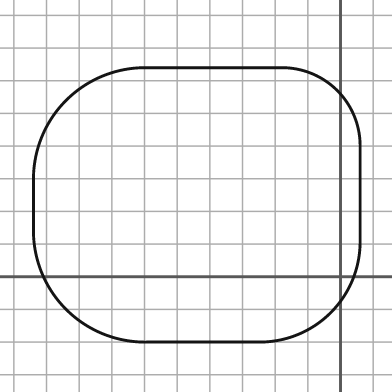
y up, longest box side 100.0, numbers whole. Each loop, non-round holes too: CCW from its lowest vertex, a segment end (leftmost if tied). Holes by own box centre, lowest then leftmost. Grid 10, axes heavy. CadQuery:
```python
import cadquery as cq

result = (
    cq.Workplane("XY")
    .moveTo(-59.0, -20.0)
    .lineTo(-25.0, -20.0)
    .threePointArc((-3.0, -11.0), (6.0, 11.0))
    .lineTo(6.0, 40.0)
    .threePointArc((-1.0, 57.0), (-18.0, 64.0))
    .lineTo(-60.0, 64.0)
    .threePointArc((-84.0, 54.0), (-94.0, 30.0))
    .lineTo(-94.0, 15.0)
    .threePointArc((-84.0, -10.0), (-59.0, -20.0))
    .close()
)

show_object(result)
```